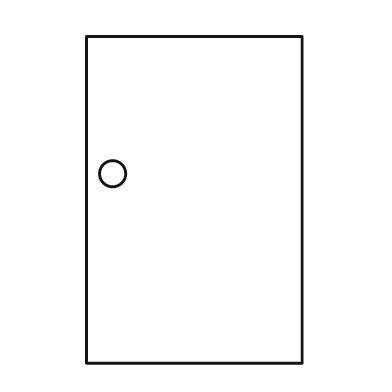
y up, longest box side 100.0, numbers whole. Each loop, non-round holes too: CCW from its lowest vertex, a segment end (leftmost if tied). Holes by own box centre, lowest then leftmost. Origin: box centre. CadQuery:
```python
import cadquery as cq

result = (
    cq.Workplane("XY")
    .moveTo(-33.0, -50.0)
    .lineTo(33.0, -50.0)
    .lineTo(33.0, 50.0)
    .lineTo(-33.0, 50.0)
    .close()
    .moveTo(-25.0, 8.0)
    .circle(4.0)
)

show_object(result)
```